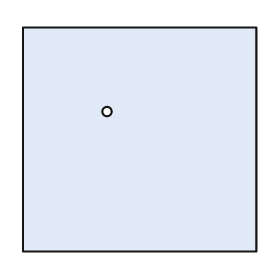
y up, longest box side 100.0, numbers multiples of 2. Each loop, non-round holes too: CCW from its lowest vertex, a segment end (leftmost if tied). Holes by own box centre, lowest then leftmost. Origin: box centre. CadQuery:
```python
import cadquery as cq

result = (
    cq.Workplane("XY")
    .moveTo(-50.0, -48.0)
    .lineTo(50.0, -48.0)
    .lineTo(50.0, 48.0)
    .lineTo(-50.0, 48.0)
    .close()
    .moveTo(-14.0, 12.0)
    .circle(2.0)
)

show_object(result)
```